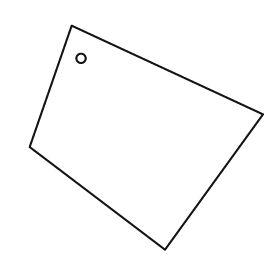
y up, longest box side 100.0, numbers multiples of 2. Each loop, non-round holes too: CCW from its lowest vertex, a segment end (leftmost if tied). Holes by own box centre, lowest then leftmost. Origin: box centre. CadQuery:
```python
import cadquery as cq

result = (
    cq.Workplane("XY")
    .moveTo(8.0, -48.0)
    .lineTo(50.0, 10.0)
    .lineTo(-32.0, 48.0)
    .lineTo(-50.0, -4.0)
    .close()
    .moveTo(-28.0, 34.0)
    .circle(2.0)
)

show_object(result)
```